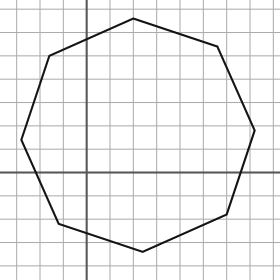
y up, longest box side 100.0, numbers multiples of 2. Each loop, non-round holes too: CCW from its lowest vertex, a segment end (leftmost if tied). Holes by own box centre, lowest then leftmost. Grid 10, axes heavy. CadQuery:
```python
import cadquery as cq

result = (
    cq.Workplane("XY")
    .moveTo(24.0, -34.0)
    .lineTo(60.0, -18.0)
    .lineTo(72.0, 18.0)
    .lineTo(56.0, 54.0)
    .lineTo(20.0, 66.0)
    .lineTo(-16.0, 50.0)
    .lineTo(-28.0, 14.0)
    .lineTo(-12.0, -22.0)
    .close()
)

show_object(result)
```